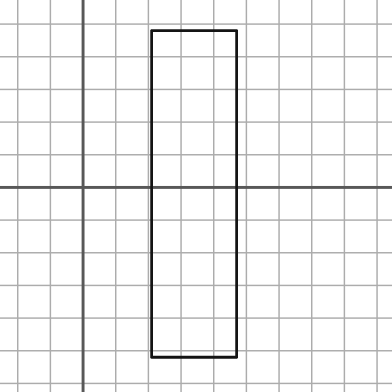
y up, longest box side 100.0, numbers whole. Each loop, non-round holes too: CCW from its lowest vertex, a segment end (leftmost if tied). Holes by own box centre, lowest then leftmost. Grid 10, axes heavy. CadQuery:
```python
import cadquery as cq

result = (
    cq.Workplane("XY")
    .moveTo(21.0, -52.0)
    .lineTo(47.0, -52.0)
    .lineTo(47.0, 48.0)
    .lineTo(21.0, 48.0)
    .close()
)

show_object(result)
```